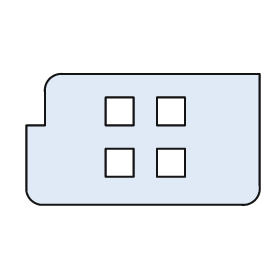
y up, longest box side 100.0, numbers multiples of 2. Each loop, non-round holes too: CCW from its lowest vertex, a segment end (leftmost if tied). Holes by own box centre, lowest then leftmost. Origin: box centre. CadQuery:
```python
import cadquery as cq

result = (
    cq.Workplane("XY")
    .moveTo(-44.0, -28.0)
    .lineTo(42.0, -28.0)
    .threePointArc((48.0, -26.0), (50.0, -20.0))
    .lineTo(50.0, 28.0)
    .lineTo(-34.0, 28.0)
    .threePointArc((-40.0, 26.0), (-42.0, 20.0))
    .lineTo(-42.0, 6.0)
    .lineTo(-50.0, 6.0)
    .lineTo(-50.0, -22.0)
    .threePointArc((-48.0, -26.0), (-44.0, -28.0))
    .close()
    .moveTo(-16.0, -16.0)
    .lineTo(-4.0, -16.0)
    .lineTo(-4.0, -4.0)
    .lineTo(-16.0, -4.0)
    .close()
    .moveTo(6.0, -16.0)
    .lineTo(18.0, -16.0)
    .lineTo(18.0, -4.0)
    .lineTo(6.0, -4.0)
    .close()
    .moveTo(-16.0, 6.0)
    .lineTo(-4.0, 6.0)
    .lineTo(-4.0, 18.0)
    .lineTo(-16.0, 18.0)
    .close()
    .moveTo(6.0, 6.0)
    .lineTo(18.0, 6.0)
    .lineTo(18.0, 18.0)
    .lineTo(6.0, 18.0)
    .close()
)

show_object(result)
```